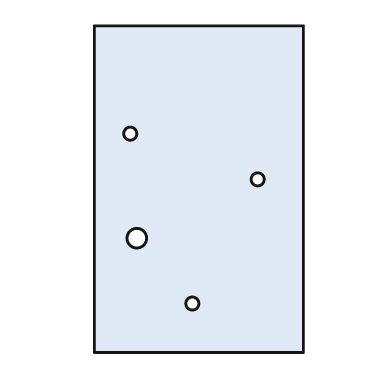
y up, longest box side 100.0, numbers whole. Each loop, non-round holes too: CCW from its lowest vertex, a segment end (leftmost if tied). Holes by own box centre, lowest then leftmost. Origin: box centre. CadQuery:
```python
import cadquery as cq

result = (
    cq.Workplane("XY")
    .moveTo(-32.0, -50.0)
    .lineTo(32.0, -50.0)
    .lineTo(32.0, 50.0)
    .lineTo(-32.0, 50.0)
    .close()
    .moveTo(-2.0, -35.0)
    .circle(2.0)
    .moveTo(-19.0, -15.0)
    .circle(3.0)
    .moveTo(18.0, 3.0)
    .circle(2.0)
    .moveTo(-21.0, 17.0)
    .circle(2.0)
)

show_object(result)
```